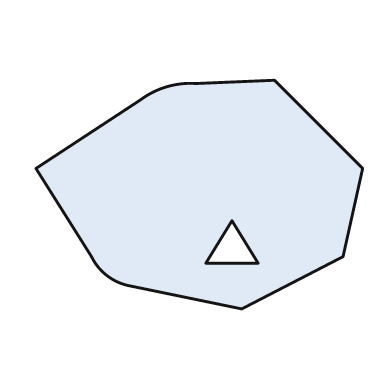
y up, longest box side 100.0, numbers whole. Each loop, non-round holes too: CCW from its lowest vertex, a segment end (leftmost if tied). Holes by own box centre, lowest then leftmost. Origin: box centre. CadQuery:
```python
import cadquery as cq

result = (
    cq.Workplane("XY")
    .moveTo(13.0, -35.0)
    .lineTo(44.0, -19.0)
    .lineTo(50.0, 8.0)
    .lineTo(23.0, 35.0)
    .lineTo(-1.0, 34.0)
    .threePointArc((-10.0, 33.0), (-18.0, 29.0))
    .lineTo(-50.0, 8.0)
    .lineTo(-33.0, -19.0)
    .threePointArc((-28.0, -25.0), (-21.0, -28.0))
    .close()
    .moveTo(2.0, -21.0)
    .lineTo(18.0, -21.0)
    .lineTo(10.0, -8.0)
    .close()
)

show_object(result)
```